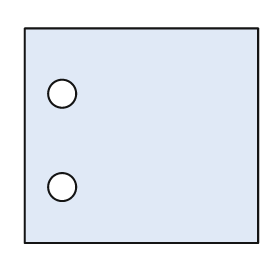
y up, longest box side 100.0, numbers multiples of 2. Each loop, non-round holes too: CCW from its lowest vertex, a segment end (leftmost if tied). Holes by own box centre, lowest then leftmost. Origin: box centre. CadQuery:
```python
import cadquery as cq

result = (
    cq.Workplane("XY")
    .moveTo(-50.0, -46.0)
    .lineTo(50.0, -46.0)
    .lineTo(50.0, 46.0)
    .lineTo(-50.0, 46.0)
    .close()
    .moveTo(-34.0, -22.0)
    .circle(6.0)
    .moveTo(-34.0, 18.0)
    .circle(6.0)
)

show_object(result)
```